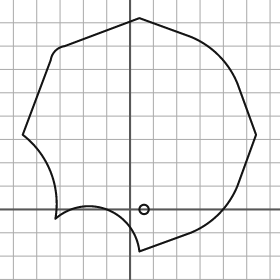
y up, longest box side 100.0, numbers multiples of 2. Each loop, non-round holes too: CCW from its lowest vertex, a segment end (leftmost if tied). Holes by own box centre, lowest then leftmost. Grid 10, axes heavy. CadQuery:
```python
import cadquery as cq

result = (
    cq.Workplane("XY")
    .moveTo(4.0, -18.0)
    .lineTo(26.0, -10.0)
    .threePointArc((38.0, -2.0), (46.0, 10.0))
    .lineTo(54.0, 32.0)
    .lineTo(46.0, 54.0)
    .threePointArc((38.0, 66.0), (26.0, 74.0))
    .lineTo(4.0, 82.0)
    .lineTo(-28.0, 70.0)
    .threePointArc((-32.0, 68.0), (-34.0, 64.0))
    .lineTo(-46.0, 32.0)
    .threePointArc((-34.0, 16.0), (-32.0, -4.0))
    .threePointArc((-10.0, 0.0), (4.0, -18.0))
    .close()
    .moveTo(6.0, 0.0)
    .circle(2.0)
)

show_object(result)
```